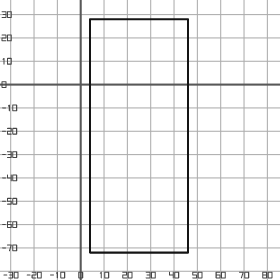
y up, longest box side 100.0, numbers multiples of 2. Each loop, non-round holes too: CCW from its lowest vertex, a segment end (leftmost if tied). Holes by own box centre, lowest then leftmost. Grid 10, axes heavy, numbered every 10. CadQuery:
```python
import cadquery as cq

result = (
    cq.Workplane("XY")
    .moveTo(4.0, -72.0)
    .lineTo(46.0, -72.0)
    .lineTo(46.0, 28.0)
    .lineTo(4.0, 28.0)
    .close()
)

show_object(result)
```